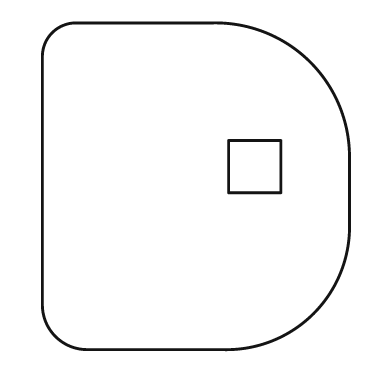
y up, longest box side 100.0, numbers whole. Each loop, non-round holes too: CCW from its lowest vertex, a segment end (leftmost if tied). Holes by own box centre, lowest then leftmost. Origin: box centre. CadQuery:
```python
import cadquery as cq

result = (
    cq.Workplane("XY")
    .moveTo(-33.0, -50.0)
    .lineTo(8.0, -50.0)
    .threePointArc((36.0, -39.0), (47.0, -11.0))
    .lineTo(47.0, 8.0)
    .threePointArc((35.0, 38.0), (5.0, 50.0))
    .lineTo(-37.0, 50.0)
    .threePointArc((-44.0, 47.0), (-47.0, 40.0))
    .lineTo(-47.0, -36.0)
    .threePointArc((-43.0, -46.0), (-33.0, -50.0))
    .close()
    .moveTo(10.0, -2.0)
    .lineTo(26.0, -2.0)
    .lineTo(26.0, 14.0)
    .lineTo(10.0, 14.0)
    .close()
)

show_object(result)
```